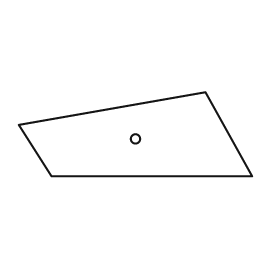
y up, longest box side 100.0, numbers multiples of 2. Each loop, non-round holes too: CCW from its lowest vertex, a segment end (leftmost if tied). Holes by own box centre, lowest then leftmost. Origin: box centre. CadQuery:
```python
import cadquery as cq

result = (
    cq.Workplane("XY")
    .moveTo(-36.0, -18.0)
    .lineTo(50.0, -18.0)
    .lineTo(30.0, 18.0)
    .lineTo(-50.0, 4.0)
    .close()
    .moveTo(0.0, -2.0)
    .circle(2.0)
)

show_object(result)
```